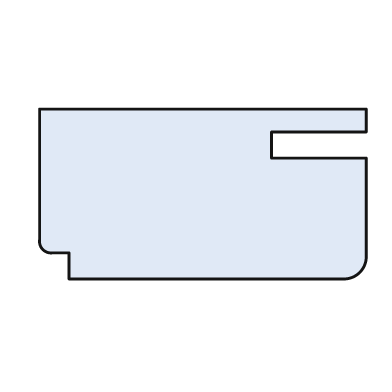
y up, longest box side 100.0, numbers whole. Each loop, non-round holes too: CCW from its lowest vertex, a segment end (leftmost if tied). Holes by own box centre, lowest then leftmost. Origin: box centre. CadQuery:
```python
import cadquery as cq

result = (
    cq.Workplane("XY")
    .moveTo(-41.0, -26.0)
    .lineTo(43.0, -26.0)
    .threePointArc((48.0, -24.0), (50.0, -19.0))
    .lineTo(50.0, 11.0)
    .lineTo(21.0, 11.0)
    .lineTo(21.0, 19.0)
    .lineTo(50.0, 19.0)
    .lineTo(50.0, 26.0)
    .lineTo(-50.0, 26.0)
    .lineTo(-50.0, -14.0)
    .threePointArc((-49.0, -17.0), (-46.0, -18.0))
    .lineTo(-41.0, -18.0)
    .close()
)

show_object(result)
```